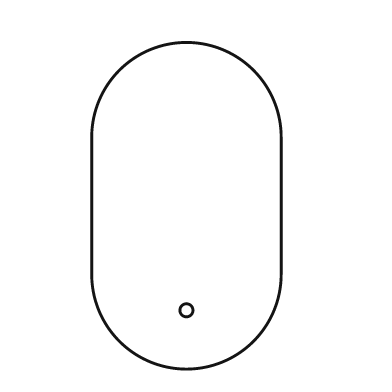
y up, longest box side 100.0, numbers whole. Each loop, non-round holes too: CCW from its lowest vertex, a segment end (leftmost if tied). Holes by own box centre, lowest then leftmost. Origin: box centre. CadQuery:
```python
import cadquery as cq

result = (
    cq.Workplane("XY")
    .moveTo(-29.0, -21.0)
    .threePointArc((0.0, -50.0), (29.0, -21.0))
    .lineTo(29.0, 21.0)
    .threePointArc((0.0, 50.0), (-29.0, 21.0))
    .close()
    .moveTo(0.0, -32.0)
    .circle(2.0)
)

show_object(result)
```